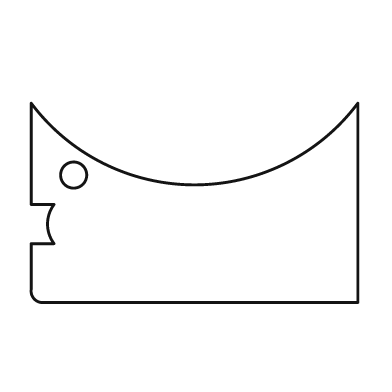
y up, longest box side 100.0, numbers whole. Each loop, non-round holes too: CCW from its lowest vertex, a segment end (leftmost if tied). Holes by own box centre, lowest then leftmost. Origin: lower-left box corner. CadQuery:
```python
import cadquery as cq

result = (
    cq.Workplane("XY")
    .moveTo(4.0, 0.0)
    .lineTo(100.0, 0.0)
    .lineTo(100.0, 61.0)
    .threePointArc((50.0, 36.0), (0.0, 61.0))
    .lineTo(0.0, 30.0)
    .lineTo(7.0, 30.0)
    .threePointArc((5.0, 24.0), (7.0, 18.0))
    .lineTo(0.0, 18.0)
    .lineTo(0.0, 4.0)
    .threePointArc((1.0, 1.0), (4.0, 0.0))
    .close()
    .moveTo(13.0, 39.0)
    .circle(4.0)
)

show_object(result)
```